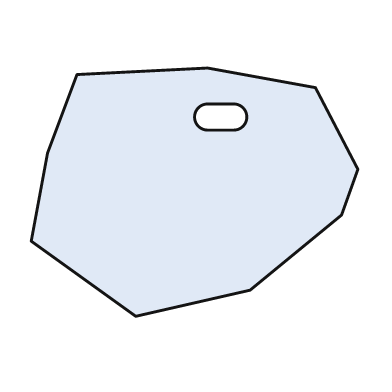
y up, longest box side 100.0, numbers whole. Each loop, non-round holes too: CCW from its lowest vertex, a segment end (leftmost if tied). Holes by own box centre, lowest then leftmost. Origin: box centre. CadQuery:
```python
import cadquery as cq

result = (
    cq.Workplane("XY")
    .moveTo(-18.0, -38.0)
    .lineTo(17.0, -30.0)
    .lineTo(45.0, -7.0)
    .lineTo(50.0, 7.0)
    .lineTo(37.0, 32.0)
    .lineTo(4.0, 38.0)
    .lineTo(-36.0, 36.0)
    .lineTo(-45.0, 12.0)
    .lineTo(-50.0, -15.0)
    .close()
    .moveTo(4.0, 19.0)
    .lineTo(12.0, 19.0)
    .threePointArc((16.0, 23.0), (12.0, 27.0))
    .lineTo(4.0, 27.0)
    .threePointArc((0.0, 23.0), (4.0, 19.0))
    .close()
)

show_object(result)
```